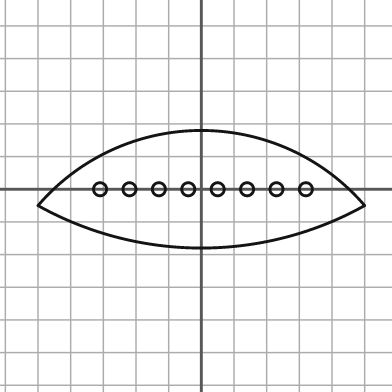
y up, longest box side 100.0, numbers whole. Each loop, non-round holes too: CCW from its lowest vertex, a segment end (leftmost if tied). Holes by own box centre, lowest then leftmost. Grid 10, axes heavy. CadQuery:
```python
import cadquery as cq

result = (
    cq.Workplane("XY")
    .moveTo(-50.0, -5.0)
    .threePointArc((0.0, -18.0), (50.0, -5.0))
    .threePointArc((0.0, 18.0), (-50.0, -5.0))
    .close()
    .moveTo(-31.0, 0.0)
    .circle(2.0)
    .moveTo(-22.0, 0.0)
    .circle(2.0)
    .moveTo(-13.0, 0.0)
    .circle(2.0)
    .moveTo(-4.0, 0.0)
    .circle(2.0)
    .moveTo(5.0, 0.0)
    .circle(2.0)
    .moveTo(14.0, 0.0)
    .circle(2.0)
    .moveTo(23.0, 0.0)
    .circle(2.0)
    .moveTo(32.0, 0.0)
    .circle(2.0)
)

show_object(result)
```